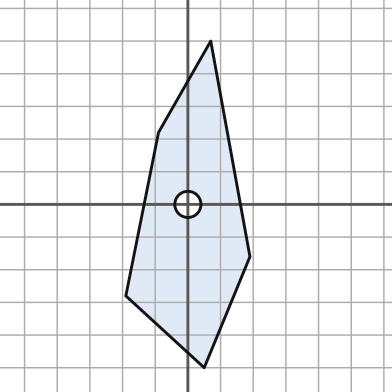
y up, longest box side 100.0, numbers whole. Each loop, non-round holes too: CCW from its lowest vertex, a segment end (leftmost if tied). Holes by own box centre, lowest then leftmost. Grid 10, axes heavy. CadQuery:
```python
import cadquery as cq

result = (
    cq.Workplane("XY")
    .moveTo(5.0, -50.0)
    .lineTo(19.0, -16.0)
    .lineTo(7.0, 50.0)
    .lineTo(-9.0, 22.0)
    .lineTo(-19.0, -28.0)
    .close()
    .moveTo(0.0, 0.0)
    .circle(4.0)
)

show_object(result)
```